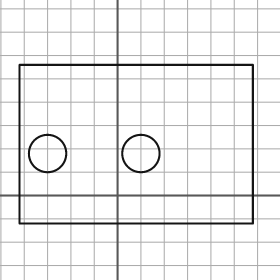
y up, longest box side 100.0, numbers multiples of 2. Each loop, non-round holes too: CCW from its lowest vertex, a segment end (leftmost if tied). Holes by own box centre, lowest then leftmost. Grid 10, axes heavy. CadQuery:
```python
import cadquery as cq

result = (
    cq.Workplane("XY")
    .moveTo(-42.0, -12.0)
    .lineTo(58.0, -12.0)
    .lineTo(58.0, 56.0)
    .lineTo(-42.0, 56.0)
    .close()
    .moveTo(-30.0, 18.0)
    .circle(8.0)
    .moveTo(10.0, 18.0)
    .circle(8.0)
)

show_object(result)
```